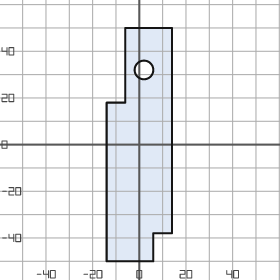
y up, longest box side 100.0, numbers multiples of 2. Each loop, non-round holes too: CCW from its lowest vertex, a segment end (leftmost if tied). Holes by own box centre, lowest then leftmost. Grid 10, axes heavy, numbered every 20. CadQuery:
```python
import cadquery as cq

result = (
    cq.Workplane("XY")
    .moveTo(-14.0, -50.0)
    .lineTo(6.0, -50.0)
    .lineTo(6.0, -38.0)
    .lineTo(14.0, -38.0)
    .lineTo(14.0, 50.0)
    .lineTo(-6.0, 50.0)
    .lineTo(-6.0, 18.0)
    .lineTo(-14.0, 18.0)
    .close()
    .moveTo(2.0, 32.0)
    .circle(4.0)
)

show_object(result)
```